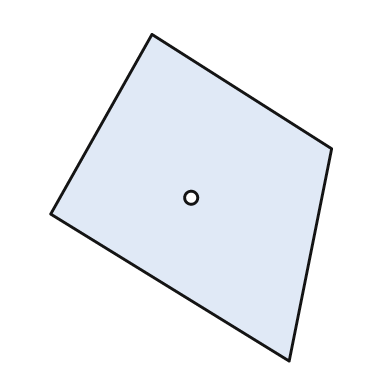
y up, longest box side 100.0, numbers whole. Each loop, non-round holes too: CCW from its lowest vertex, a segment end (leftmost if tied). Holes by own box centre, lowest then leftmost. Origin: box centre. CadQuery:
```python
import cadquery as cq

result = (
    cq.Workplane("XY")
    .moveTo(30.0, -50.0)
    .lineTo(43.0, 15.0)
    .lineTo(-12.0, 50.0)
    .lineTo(-43.0, -5.0)
    .close()
    .moveTo(0.0, 0.0)
    .circle(2.0)
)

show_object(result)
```